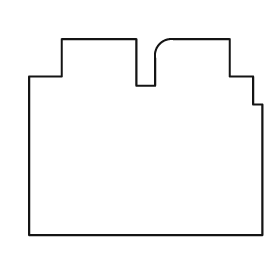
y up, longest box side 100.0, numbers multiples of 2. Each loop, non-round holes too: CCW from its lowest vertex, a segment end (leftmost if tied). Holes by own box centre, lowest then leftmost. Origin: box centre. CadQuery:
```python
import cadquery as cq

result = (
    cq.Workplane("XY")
    .moveTo(-50.0, -42.0)
    .lineTo(50.0, -42.0)
    .lineTo(50.0, 14.0)
    .lineTo(46.0, 14.0)
    .lineTo(46.0, 26.0)
    .lineTo(36.0, 26.0)
    .lineTo(36.0, 42.0)
    .lineTo(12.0, 42.0)
    .threePointArc((6.0, 40.0), (4.0, 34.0))
    .lineTo(4.0, 22.0)
    .lineTo(-4.0, 22.0)
    .lineTo(-4.0, 42.0)
    .lineTo(-36.0, 42.0)
    .lineTo(-36.0, 26.0)
    .lineTo(-50.0, 26.0)
    .close()
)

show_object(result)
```